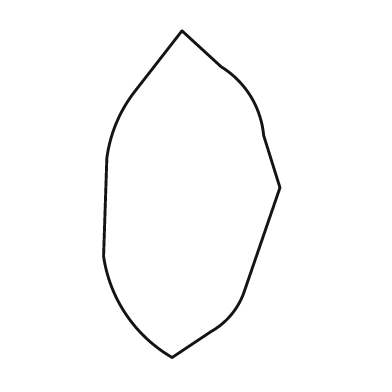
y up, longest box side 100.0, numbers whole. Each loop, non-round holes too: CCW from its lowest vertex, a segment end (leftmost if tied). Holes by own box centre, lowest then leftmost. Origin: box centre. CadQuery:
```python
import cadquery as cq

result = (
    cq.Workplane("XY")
    .moveTo(-6.0, -50.0)
    .lineTo(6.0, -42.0)
    .threePointArc((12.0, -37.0), (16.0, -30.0))
    .lineTo(27.0, 2.0)
    .lineTo(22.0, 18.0)
    .threePointArc((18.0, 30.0), (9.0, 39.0))
    .lineTo(-3.0, 50.0)
    .lineTo(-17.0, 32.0)
    .threePointArc((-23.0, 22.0), (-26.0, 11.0))
    .lineTo(-27.0, -19.0)
    .threePointArc((-20.0, -37.0), (-6.0, -50.0))
    .close()
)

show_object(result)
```